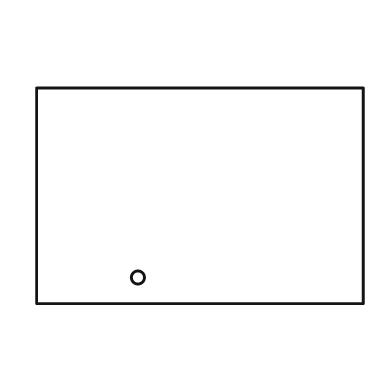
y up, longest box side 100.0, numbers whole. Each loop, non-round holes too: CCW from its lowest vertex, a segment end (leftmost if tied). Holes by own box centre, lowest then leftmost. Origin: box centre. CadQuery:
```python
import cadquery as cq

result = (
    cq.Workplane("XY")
    .moveTo(-50.0, -33.0)
    .lineTo(50.0, -33.0)
    .lineTo(50.0, 33.0)
    .lineTo(-50.0, 33.0)
    .close()
    .moveTo(-19.0, -25.0)
    .circle(2.0)
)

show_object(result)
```